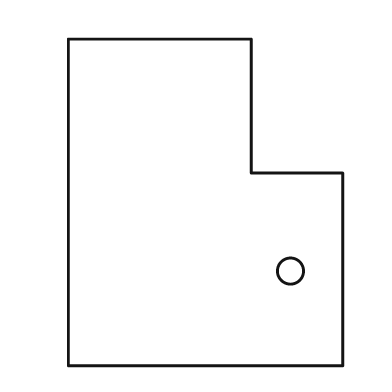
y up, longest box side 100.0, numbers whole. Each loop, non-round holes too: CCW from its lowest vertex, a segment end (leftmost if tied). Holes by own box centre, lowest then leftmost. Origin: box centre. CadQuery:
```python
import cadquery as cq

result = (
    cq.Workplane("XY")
    .moveTo(-42.0, -50.0)
    .lineTo(42.0, -50.0)
    .lineTo(42.0, 9.0)
    .lineTo(14.0, 9.0)
    .lineTo(14.0, 50.0)
    .lineTo(-42.0, 50.0)
    .close()
    .moveTo(26.0, -21.0)
    .circle(4.0)
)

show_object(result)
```